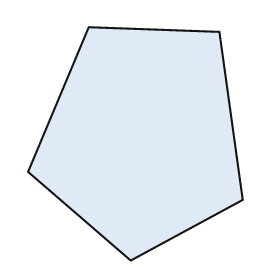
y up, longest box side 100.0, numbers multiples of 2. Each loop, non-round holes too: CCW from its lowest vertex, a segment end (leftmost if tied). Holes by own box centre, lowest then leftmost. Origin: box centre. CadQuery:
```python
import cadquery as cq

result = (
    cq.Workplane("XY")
    .moveTo(-2.0, -50.0)
    .lineTo(46.0, -24.0)
    .lineTo(36.0, 48.0)
    .lineTo(-20.0, 50.0)
    .lineTo(-46.0, -12.0)
    .close()
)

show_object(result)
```